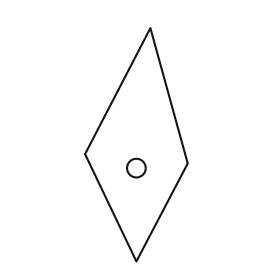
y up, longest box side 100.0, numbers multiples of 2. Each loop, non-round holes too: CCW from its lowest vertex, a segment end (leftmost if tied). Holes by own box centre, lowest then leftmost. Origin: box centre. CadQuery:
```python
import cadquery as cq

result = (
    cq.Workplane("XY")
    .moveTo(0.0, -50.0)
    .lineTo(22.0, -8.0)
    .lineTo(6.0, 50.0)
    .lineTo(-22.0, -4.0)
    .close()
    .moveTo(0.0, -10.0)
    .circle(4.0)
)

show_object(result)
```